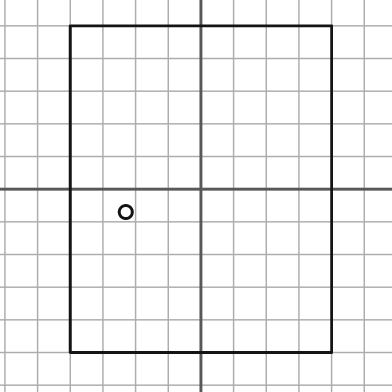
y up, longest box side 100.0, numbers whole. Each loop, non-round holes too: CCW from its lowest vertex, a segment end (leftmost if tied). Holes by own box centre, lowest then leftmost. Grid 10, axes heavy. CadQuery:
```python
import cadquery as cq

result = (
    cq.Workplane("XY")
    .moveTo(-40.0, -50.0)
    .lineTo(40.0, -50.0)
    .lineTo(40.0, 50.0)
    .lineTo(-40.0, 50.0)
    .close()
    .moveTo(-23.0, -7.0)
    .circle(2.0)
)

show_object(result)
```